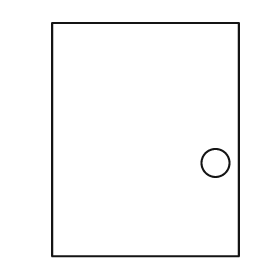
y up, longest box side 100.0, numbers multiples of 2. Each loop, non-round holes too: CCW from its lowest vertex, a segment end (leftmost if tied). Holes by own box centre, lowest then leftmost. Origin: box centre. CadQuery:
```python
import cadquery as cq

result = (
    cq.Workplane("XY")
    .moveTo(-40.0, -50.0)
    .lineTo(40.0, -50.0)
    .lineTo(40.0, 50.0)
    .lineTo(-40.0, 50.0)
    .close()
    .moveTo(30.0, -10.0)
    .circle(6.0)
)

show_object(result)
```